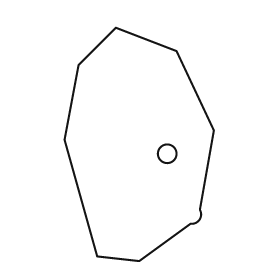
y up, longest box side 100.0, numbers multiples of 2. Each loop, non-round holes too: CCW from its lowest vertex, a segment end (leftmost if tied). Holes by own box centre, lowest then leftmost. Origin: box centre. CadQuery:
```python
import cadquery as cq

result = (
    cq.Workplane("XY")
    .moveTo(0.0, -50.0)
    .lineTo(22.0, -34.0)
    .threePointArc((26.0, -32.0), (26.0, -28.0))
    .lineTo(32.0, 6.0)
    .lineTo(16.0, 40.0)
    .lineTo(-10.0, 50.0)
    .lineTo(-26.0, 34.0)
    .lineTo(-32.0, 2.0)
    .lineTo(-18.0, -48.0)
    .close()
    .moveTo(12.0, -4.0)
    .circle(4.0)
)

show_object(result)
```